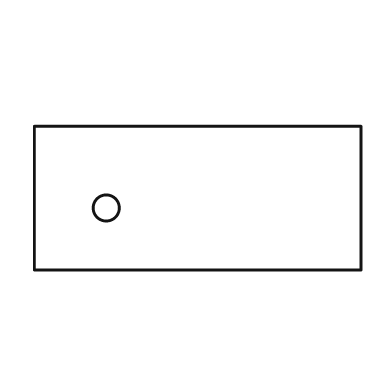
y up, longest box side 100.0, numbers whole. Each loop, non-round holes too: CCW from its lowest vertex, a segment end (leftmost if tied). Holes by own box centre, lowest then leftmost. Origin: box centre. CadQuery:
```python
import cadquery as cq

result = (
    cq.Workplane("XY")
    .moveTo(-50.0, -22.0)
    .lineTo(50.0, -22.0)
    .lineTo(50.0, 22.0)
    .lineTo(-50.0, 22.0)
    .close()
    .moveTo(-28.0, -3.0)
    .circle(4.0)
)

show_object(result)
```